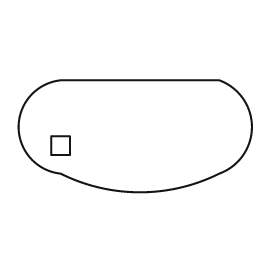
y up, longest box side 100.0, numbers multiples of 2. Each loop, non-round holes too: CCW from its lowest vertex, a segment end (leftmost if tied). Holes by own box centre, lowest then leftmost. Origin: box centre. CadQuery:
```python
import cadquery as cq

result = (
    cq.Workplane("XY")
    .moveTo(-32.0, -16.0)
    .threePointArc((2.0, -24.0), (36.0, -16.0))
    .threePointArc((50.0, 4.0), (36.0, 24.0))
    .lineTo(-32.0, 24.0)
    .threePointArc((-50.0, 4.0), (-32.0, -16.0))
    .close()
    .moveTo(-36.0, -8.0)
    .lineTo(-28.0, -8.0)
    .lineTo(-28.0, 0.0)
    .lineTo(-36.0, 0.0)
    .close()
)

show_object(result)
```